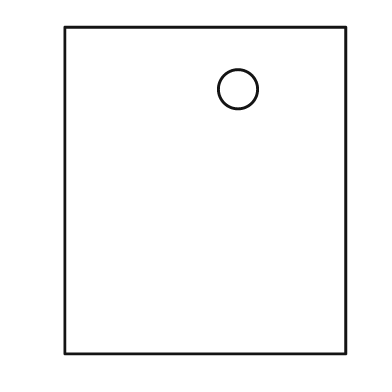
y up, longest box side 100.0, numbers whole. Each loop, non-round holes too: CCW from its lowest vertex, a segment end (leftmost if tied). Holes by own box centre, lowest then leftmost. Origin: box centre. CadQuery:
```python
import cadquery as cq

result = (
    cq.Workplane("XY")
    .moveTo(-43.0, -50.0)
    .lineTo(43.0, -50.0)
    .lineTo(43.0, 50.0)
    .lineTo(-43.0, 50.0)
    .close()
    .moveTo(10.0, 31.0)
    .circle(6.0)
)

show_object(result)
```